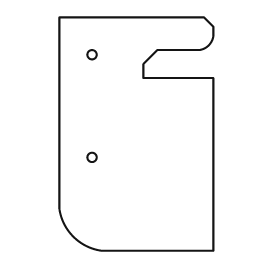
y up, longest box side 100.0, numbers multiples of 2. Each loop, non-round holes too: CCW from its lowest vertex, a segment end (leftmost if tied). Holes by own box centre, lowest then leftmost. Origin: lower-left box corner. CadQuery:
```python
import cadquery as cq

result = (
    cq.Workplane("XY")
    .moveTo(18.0, 0.0)
    .lineTo(66.0, 0.0)
    .lineTo(66.0, 74.0)
    .lineTo(36.0, 74.0)
    .lineTo(36.0, 80.0)
    .lineTo(42.0, 86.0)
    .lineTo(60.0, 86.0)
    .threePointArc((64.0, 88.0), (66.0, 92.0))
    .lineTo(66.0, 96.0)
    .lineTo(62.0, 100.0)
    .lineTo(0.0, 100.0)
    .lineTo(0.0, 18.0)
    .threePointArc((6.0, 6.0), (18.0, 0.0))
    .close()
    .moveTo(14.0, 40.0)
    .circle(2.0)
    .moveTo(14.0, 84.0)
    .circle(2.0)
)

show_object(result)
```